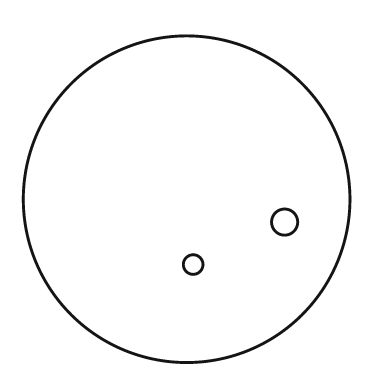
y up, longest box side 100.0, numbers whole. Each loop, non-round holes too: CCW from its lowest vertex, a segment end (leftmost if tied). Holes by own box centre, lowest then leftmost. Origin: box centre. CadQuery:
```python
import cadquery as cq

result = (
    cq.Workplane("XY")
    .moveTo(0.0, 0.0)
    .circle(50.0)
    .moveTo(2.0, -20.0)
    .circle(3.0)
    .moveTo(30.0, -7.0)
    .circle(4.0)
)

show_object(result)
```